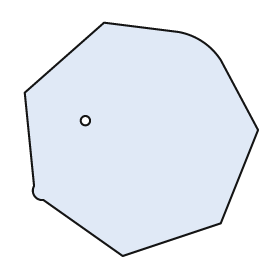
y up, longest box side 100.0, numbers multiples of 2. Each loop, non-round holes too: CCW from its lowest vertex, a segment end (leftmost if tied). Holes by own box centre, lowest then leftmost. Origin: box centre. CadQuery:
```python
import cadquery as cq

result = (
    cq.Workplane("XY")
    .moveTo(-8.0, -50.0)
    .lineTo(34.0, -36.0)
    .lineTo(50.0, 4.0)
    .lineTo(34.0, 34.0)
    .threePointArc((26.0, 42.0), (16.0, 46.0))
    .lineTo(-16.0, 50.0)
    .lineTo(-50.0, 20.0)
    .lineTo(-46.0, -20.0)
    .threePointArc((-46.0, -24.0), (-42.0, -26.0))
    .close()
    .moveTo(-24.0, 8.0)
    .circle(2.0)
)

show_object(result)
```